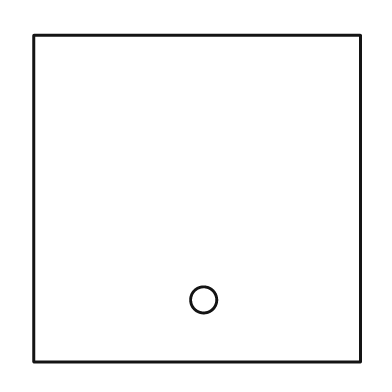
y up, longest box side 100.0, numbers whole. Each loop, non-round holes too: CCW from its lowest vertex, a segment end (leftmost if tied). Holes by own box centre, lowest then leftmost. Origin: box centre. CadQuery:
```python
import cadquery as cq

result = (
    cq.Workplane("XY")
    .moveTo(-50.0, -50.0)
    .lineTo(50.0, -50.0)
    .lineTo(50.0, 50.0)
    .lineTo(-50.0, 50.0)
    .close()
    .moveTo(2.0, -31.0)
    .circle(4.0)
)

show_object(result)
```